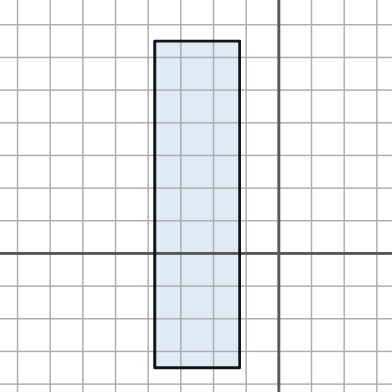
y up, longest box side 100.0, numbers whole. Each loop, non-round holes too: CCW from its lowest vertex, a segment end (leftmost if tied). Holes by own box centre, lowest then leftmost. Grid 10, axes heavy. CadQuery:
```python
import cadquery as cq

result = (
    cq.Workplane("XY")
    .moveTo(-38.0, -35.0)
    .lineTo(-12.0, -35.0)
    .lineTo(-12.0, 65.0)
    .lineTo(-38.0, 65.0)
    .close()
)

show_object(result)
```